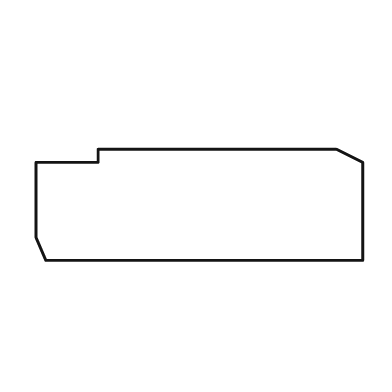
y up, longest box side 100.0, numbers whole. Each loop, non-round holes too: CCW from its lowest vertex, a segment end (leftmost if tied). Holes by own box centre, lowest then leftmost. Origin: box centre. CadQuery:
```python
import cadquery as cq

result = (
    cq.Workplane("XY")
    .moveTo(-47.0, -17.0)
    .lineTo(50.0, -17.0)
    .lineTo(50.0, 13.0)
    .lineTo(42.0, 17.0)
    .lineTo(-31.0, 17.0)
    .lineTo(-31.0, 13.0)
    .lineTo(-50.0, 13.0)
    .lineTo(-50.0, -10.0)
    .close()
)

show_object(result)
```